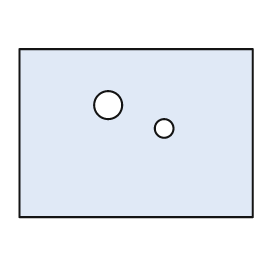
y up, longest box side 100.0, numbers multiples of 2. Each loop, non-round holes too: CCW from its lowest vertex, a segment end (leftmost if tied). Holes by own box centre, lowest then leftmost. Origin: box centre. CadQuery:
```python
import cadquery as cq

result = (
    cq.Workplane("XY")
    .moveTo(-50.0, -36.0)
    .lineTo(50.0, -36.0)
    .lineTo(50.0, 36.0)
    .lineTo(-50.0, 36.0)
    .close()
    .moveTo(12.0, 2.0)
    .circle(4.0)
    .moveTo(-12.0, 12.0)
    .circle(6.0)
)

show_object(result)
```